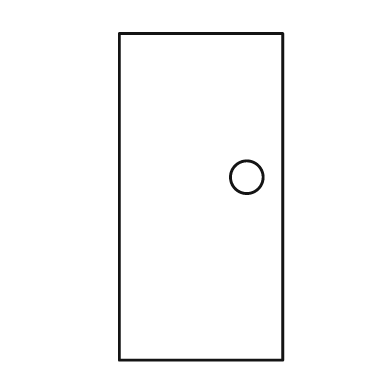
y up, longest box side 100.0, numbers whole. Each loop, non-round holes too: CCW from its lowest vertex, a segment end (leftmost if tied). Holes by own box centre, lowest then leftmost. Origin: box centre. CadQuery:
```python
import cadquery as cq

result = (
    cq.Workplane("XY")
    .moveTo(-25.0, -50.0)
    .lineTo(25.0, -50.0)
    .lineTo(25.0, 50.0)
    .lineTo(-25.0, 50.0)
    .close()
    .moveTo(14.0, 6.0)
    .circle(5.0)
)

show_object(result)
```